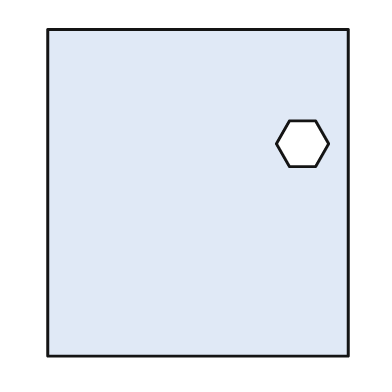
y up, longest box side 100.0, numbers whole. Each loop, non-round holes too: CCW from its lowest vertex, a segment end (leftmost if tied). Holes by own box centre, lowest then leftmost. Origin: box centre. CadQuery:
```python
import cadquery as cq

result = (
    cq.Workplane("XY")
    .moveTo(-46.0, -50.0)
    .lineTo(46.0, -50.0)
    .lineTo(46.0, 50.0)
    .lineTo(-46.0, 50.0)
    .close()
    .moveTo(28.0, 8.0)
    .lineTo(36.0, 8.0)
    .lineTo(40.0, 15.0)
    .lineTo(36.0, 22.0)
    .lineTo(28.0, 22.0)
    .lineTo(24.0, 15.0)
    .close()
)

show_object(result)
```